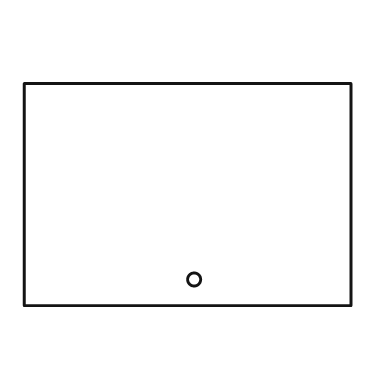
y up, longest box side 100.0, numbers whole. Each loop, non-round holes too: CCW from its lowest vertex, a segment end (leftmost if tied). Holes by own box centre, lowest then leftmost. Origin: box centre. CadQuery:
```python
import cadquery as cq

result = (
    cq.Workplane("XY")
    .moveTo(-50.0, -34.0)
    .lineTo(50.0, -34.0)
    .lineTo(50.0, 34.0)
    .lineTo(-50.0, 34.0)
    .close()
    .moveTo(2.0, -26.0)
    .circle(2.0)
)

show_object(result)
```